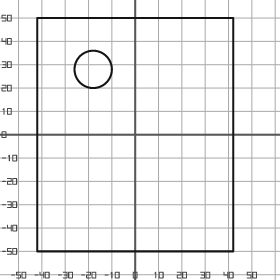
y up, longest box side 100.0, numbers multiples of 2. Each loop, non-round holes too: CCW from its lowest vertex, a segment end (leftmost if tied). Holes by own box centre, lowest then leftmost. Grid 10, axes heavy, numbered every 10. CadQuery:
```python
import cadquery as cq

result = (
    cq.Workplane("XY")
    .moveTo(-42.0, -50.0)
    .lineTo(42.0, -50.0)
    .lineTo(42.0, 50.0)
    .lineTo(-42.0, 50.0)
    .close()
    .moveTo(-18.0, 28.0)
    .circle(8.0)
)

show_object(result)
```